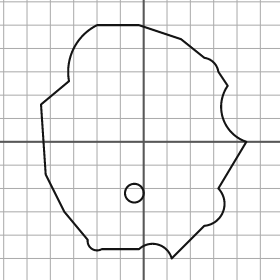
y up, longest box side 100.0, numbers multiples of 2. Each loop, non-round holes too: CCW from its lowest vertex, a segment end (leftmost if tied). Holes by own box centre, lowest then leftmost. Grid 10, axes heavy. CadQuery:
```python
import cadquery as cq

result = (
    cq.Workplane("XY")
    .moveTo(12.0, -50.0)
    .lineTo(26.0, -36.0)
    .threePointArc((34.0, -30.0), (32.0, -20.0))
    .lineTo(44.0, 0.0)
    .threePointArc((34.0, 10.0), (36.0, 24.0))
    .lineTo(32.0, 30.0)
    .threePointArc((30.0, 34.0), (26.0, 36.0))
    .lineTo(16.0, 44.0)
    .lineTo(-2.0, 50.0)
    .lineTo(-20.0, 50.0)
    .threePointArc((-30.0, 40.0), (-32.0, 26.0))
    .lineTo(-44.0, 16.0)
    .lineTo(-42.0, -14.0)
    .lineTo(-34.0, -30.0)
    .lineTo(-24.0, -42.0)
    .threePointArc((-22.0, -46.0), (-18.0, -46.0))
    .lineTo(-2.0, -46.0)
    .threePointArc((6.0, -44.0), (12.0, -50.0))
    .close()
    .moveTo(-4.0, -22.0)
    .circle(4.0)
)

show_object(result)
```